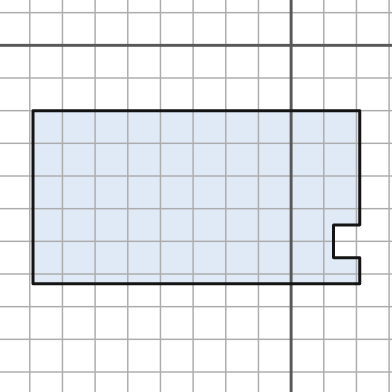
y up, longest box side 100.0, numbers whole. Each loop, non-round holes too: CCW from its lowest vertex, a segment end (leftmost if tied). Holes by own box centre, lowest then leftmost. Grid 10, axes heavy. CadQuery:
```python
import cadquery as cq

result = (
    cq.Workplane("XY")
    .moveTo(-79.0, -73.0)
    .lineTo(21.0, -73.0)
    .lineTo(21.0, -65.0)
    .lineTo(13.0, -65.0)
    .lineTo(13.0, -55.0)
    .lineTo(21.0, -55.0)
    .lineTo(21.0, -20.0)
    .lineTo(-79.0, -20.0)
    .close()
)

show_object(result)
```